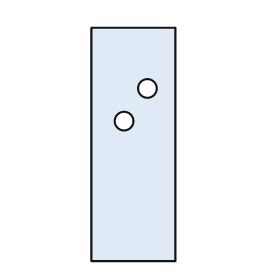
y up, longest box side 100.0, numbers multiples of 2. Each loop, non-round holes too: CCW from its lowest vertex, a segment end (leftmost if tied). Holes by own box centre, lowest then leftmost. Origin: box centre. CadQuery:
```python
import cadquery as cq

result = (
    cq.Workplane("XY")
    .moveTo(-18.0, -50.0)
    .lineTo(18.0, -50.0)
    .lineTo(18.0, 50.0)
    .lineTo(-18.0, 50.0)
    .close()
    .moveTo(-4.0, 10.0)
    .circle(4.0)
    .moveTo(6.0, 24.0)
    .circle(4.0)
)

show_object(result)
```